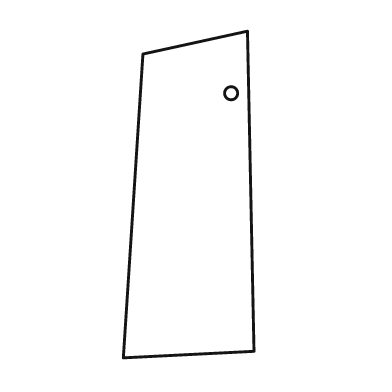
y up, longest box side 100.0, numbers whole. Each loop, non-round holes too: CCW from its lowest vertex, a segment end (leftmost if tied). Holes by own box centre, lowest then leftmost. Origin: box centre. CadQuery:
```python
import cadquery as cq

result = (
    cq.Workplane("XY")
    .moveTo(-20.0, -50.0)
    .lineTo(20.0, -48.0)
    .lineTo(18.0, 50.0)
    .lineTo(-14.0, 43.0)
    .close()
    .moveTo(13.0, 31.0)
    .circle(2.0)
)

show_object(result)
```